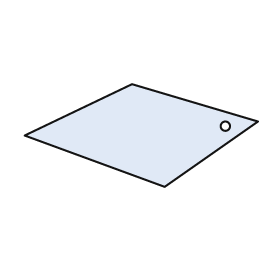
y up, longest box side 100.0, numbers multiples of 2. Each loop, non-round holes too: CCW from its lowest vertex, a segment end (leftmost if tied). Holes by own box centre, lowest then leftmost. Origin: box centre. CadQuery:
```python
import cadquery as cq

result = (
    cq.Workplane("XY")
    .moveTo(10.0, -22.0)
    .lineTo(50.0, 6.0)
    .lineTo(-4.0, 22.0)
    .lineTo(-50.0, 0.0)
    .close()
    .moveTo(36.0, 4.0)
    .circle(2.0)
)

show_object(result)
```